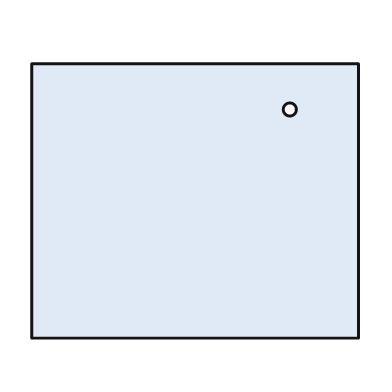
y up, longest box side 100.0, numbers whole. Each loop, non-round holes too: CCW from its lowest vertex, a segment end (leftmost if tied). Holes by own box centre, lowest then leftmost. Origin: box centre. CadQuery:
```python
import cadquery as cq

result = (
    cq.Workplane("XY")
    .moveTo(-50.0, -42.0)
    .lineTo(50.0, -42.0)
    .lineTo(50.0, 42.0)
    .lineTo(-50.0, 42.0)
    .close()
    .moveTo(29.0, 28.0)
    .circle(2.0)
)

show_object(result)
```